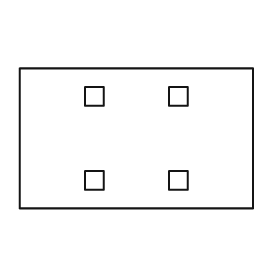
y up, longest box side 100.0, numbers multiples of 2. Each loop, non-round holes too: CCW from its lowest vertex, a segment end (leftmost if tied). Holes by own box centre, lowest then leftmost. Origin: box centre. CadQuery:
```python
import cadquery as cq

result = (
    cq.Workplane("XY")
    .moveTo(-50.0, -30.0)
    .lineTo(50.0, -30.0)
    .lineTo(50.0, 30.0)
    .lineTo(-50.0, 30.0)
    .close()
    .moveTo(-22.0, -22.0)
    .lineTo(-14.0, -22.0)
    .lineTo(-14.0, -14.0)
    .lineTo(-22.0, -14.0)
    .close()
    .moveTo(14.0, -22.0)
    .lineTo(22.0, -22.0)
    .lineTo(22.0, -14.0)
    .lineTo(14.0, -14.0)
    .close()
    .moveTo(-22.0, 14.0)
    .lineTo(-14.0, 14.0)
    .lineTo(-14.0, 22.0)
    .lineTo(-22.0, 22.0)
    .close()
    .moveTo(14.0, 14.0)
    .lineTo(22.0, 14.0)
    .lineTo(22.0, 22.0)
    .lineTo(14.0, 22.0)
    .close()
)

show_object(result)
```